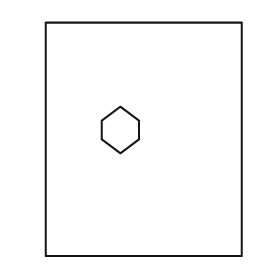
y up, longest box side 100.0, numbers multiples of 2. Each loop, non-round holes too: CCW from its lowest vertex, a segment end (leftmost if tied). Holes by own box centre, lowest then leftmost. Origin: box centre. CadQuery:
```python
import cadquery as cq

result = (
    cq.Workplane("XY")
    .moveTo(-42.0, -50.0)
    .lineTo(42.0, -50.0)
    .lineTo(42.0, 50.0)
    .lineTo(-42.0, 50.0)
    .close()
    .moveTo(-10.0, -6.0)
    .lineTo(-2.0, 0.0)
    .lineTo(-2.0, 8.0)
    .lineTo(-10.0, 14.0)
    .lineTo(-18.0, 8.0)
    .lineTo(-18.0, 0.0)
    .close()
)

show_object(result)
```